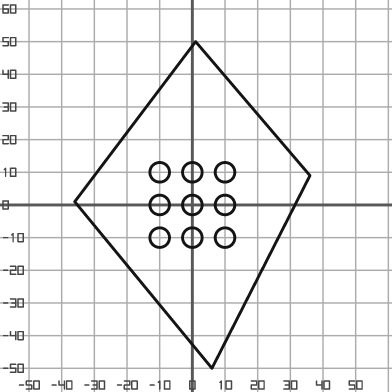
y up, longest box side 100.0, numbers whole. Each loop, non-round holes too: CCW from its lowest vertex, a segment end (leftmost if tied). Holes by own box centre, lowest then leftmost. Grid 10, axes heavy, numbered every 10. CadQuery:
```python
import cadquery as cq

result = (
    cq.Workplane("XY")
    .moveTo(6.0, -50.0)
    .lineTo(36.0, 9.0)
    .lineTo(1.0, 50.0)
    .lineTo(-36.0, 1.0)
    .close()
    .moveTo(-10.0, -10.0)
    .circle(3.0)
    .moveTo(0.0, -10.0)
    .circle(3.0)
    .moveTo(10.0, -10.0)
    .circle(3.0)
    .moveTo(-10.0, 0.0)
    .circle(3.0)
    .moveTo(0.0, 0.0)
    .circle(3.0)
    .moveTo(10.0, 0.0)
    .circle(3.0)
    .moveTo(-10.0, 10.0)
    .circle(3.0)
    .moveTo(0.0, 10.0)
    .circle(3.0)
    .moveTo(10.0, 10.0)
    .circle(3.0)
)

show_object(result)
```